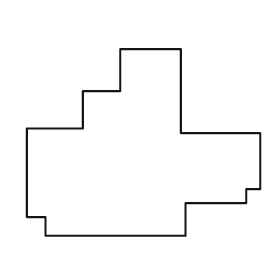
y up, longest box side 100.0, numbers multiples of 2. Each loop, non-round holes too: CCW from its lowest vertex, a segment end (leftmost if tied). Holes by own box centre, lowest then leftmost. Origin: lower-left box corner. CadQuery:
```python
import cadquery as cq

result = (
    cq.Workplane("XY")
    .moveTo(8.0, 0.0)
    .lineTo(68.0, 0.0)
    .lineTo(68.0, 14.0)
    .lineTo(94.0, 14.0)
    .lineTo(94.0, 20.0)
    .lineTo(100.0, 20.0)
    .lineTo(100.0, 44.0)
    .lineTo(66.0, 44.0)
    .lineTo(66.0, 80.0)
    .lineTo(40.0, 80.0)
    .lineTo(40.0, 62.0)
    .lineTo(24.0, 62.0)
    .lineTo(24.0, 46.0)
    .lineTo(0.0, 46.0)
    .lineTo(0.0, 8.0)
    .lineTo(8.0, 8.0)
    .close()
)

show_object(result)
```